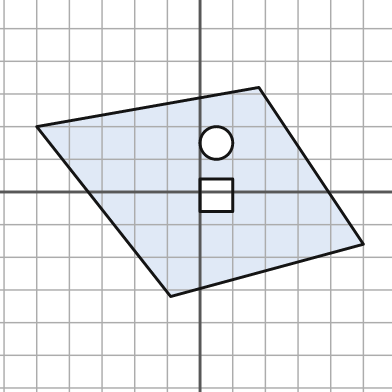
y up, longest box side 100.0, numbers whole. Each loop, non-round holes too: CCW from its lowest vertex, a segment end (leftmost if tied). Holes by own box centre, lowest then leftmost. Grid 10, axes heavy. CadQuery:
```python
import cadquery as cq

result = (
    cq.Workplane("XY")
    .moveTo(-9.0, -32.0)
    .lineTo(50.0, -16.0)
    .lineTo(18.0, 32.0)
    .lineTo(-50.0, 20.0)
    .close()
    .moveTo(0.0, -6.0)
    .lineTo(10.0, -6.0)
    .lineTo(10.0, 4.0)
    .lineTo(0.0, 4.0)
    .close()
    .moveTo(5.0, 15.0)
    .circle(5.0)
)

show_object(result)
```